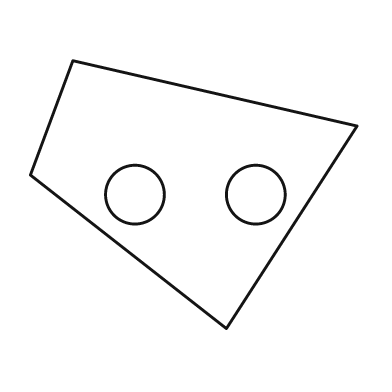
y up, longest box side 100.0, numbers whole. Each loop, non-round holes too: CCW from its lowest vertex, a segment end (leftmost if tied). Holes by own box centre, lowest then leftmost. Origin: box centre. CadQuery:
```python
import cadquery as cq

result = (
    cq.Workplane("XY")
    .moveTo(10.0, -41.0)
    .lineTo(50.0, 21.0)
    .lineTo(-37.0, 41.0)
    .lineTo(-50.0, 6.0)
    .close()
    .moveTo(-18.0, 0.0)
    .circle(9.0)
    .moveTo(19.0, 0.0)
    .circle(9.0)
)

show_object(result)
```